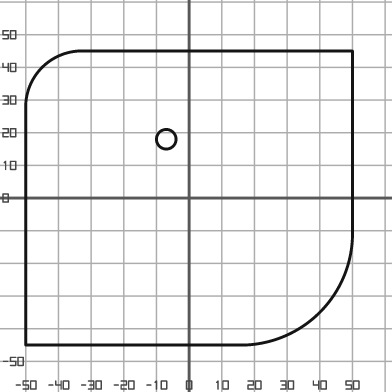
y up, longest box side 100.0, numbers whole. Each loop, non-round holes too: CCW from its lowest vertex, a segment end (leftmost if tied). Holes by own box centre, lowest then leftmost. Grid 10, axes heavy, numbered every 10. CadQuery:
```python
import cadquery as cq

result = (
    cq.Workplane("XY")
    .moveTo(-50.0, -45.0)
    .lineTo(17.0, -45.0)
    .threePointArc((40.0, -35.0), (50.0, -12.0))
    .lineTo(50.0, 45.0)
    .lineTo(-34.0, 45.0)
    .threePointArc((-45.0, 40.0), (-50.0, 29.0))
    .close()
    .moveTo(-7.0, 18.0)
    .circle(3.0)
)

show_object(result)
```